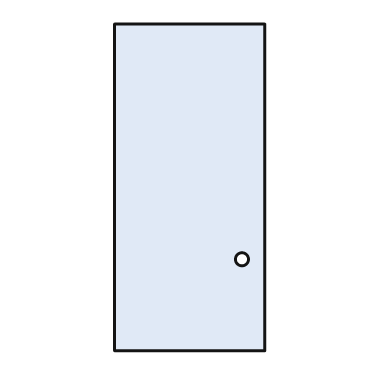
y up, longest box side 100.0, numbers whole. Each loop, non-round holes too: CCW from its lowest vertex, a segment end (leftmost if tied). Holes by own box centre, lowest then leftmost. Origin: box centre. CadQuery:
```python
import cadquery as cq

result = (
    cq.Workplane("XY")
    .moveTo(-23.0, -50.0)
    .lineTo(23.0, -50.0)
    .lineTo(23.0, 50.0)
    .lineTo(-23.0, 50.0)
    .close()
    .moveTo(16.0, -22.0)
    .circle(2.0)
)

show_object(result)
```